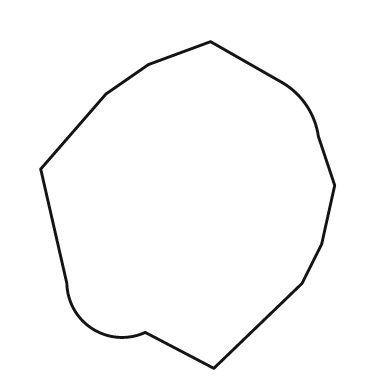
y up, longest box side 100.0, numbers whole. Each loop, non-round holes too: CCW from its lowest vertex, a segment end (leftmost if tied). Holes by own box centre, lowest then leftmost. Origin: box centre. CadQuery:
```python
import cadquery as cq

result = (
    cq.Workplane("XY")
    .moveTo(8.0, -50.0)
    .lineTo(35.0, -24.0)
    .lineTo(41.0, -12.0)
    .lineTo(45.0, 6.0)
    .lineTo(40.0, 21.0)
    .threePointArc((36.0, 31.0), (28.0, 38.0))
    .lineTo(7.0, 50.0)
    .lineTo(-12.0, 43.0)
    .lineTo(-25.0, 34.0)
    .lineTo(-45.0, 11.0)
    .lineTo(-37.0, -24.0)
    .threePointArc((-29.0, -38.0), (-13.0, -39.0))
    .close()
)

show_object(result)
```